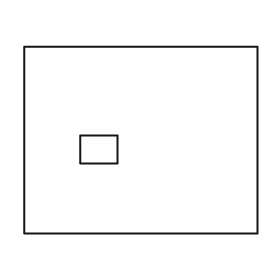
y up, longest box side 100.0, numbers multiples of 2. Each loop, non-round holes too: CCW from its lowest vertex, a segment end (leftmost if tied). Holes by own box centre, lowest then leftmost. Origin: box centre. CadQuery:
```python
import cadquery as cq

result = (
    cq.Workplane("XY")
    .moveTo(-50.0, -40.0)
    .lineTo(50.0, -40.0)
    .lineTo(50.0, 40.0)
    .lineTo(-50.0, 40.0)
    .close()
    .moveTo(-26.0, -10.0)
    .lineTo(-10.0, -10.0)
    .lineTo(-10.0, 2.0)
    .lineTo(-26.0, 2.0)
    .close()
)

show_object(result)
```